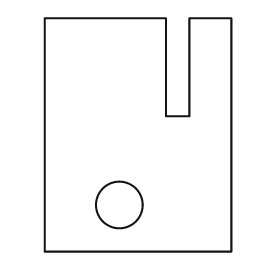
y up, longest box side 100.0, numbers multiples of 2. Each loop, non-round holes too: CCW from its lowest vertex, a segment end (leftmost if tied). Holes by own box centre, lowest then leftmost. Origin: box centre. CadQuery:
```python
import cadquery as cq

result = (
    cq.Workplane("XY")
    .moveTo(-40.0, -50.0)
    .lineTo(40.0, -50.0)
    .lineTo(40.0, 50.0)
    .lineTo(22.0, 50.0)
    .lineTo(22.0, 8.0)
    .lineTo(12.0, 8.0)
    .lineTo(12.0, 50.0)
    .lineTo(-40.0, 50.0)
    .close()
    .moveTo(-8.0, -30.0)
    .circle(10.0)
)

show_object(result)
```